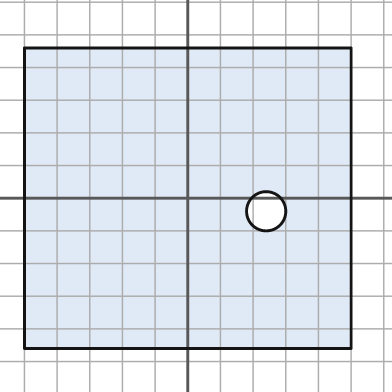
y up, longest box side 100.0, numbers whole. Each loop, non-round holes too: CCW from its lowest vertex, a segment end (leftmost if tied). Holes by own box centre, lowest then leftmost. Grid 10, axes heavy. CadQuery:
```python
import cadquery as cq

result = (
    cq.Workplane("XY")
    .moveTo(-50.0, -46.0)
    .lineTo(50.0, -46.0)
    .lineTo(50.0, 46.0)
    .lineTo(-50.0, 46.0)
    .close()
    .moveTo(24.0, -4.0)
    .circle(6.0)
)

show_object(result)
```